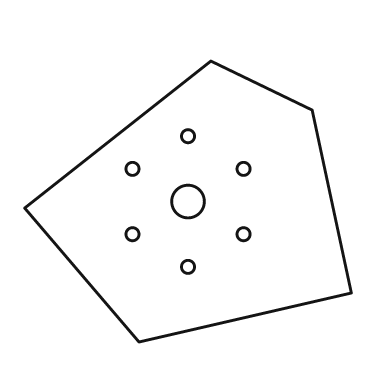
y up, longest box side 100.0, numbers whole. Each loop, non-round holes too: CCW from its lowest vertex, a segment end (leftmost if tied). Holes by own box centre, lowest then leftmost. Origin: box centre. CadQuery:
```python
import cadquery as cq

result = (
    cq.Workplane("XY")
    .moveTo(-15.0, -43.0)
    .lineTo(50.0, -28.0)
    .lineTo(38.0, 28.0)
    .lineTo(7.0, 43.0)
    .lineTo(-50.0, -2.0)
    .close()
    .moveTo(0.0, -20.0)
    .circle(2.0)
    .moveTo(-17.0, -10.0)
    .circle(2.0)
    .moveTo(17.0, -10.0)
    .circle(2.0)
    .moveTo(0.0, 0.0)
    .circle(5.0)
    .moveTo(-17.0, 10.0)
    .circle(2.0)
    .moveTo(17.0, 10.0)
    .circle(2.0)
    .moveTo(0.0, 20.0)
    .circle(2.0)
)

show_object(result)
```